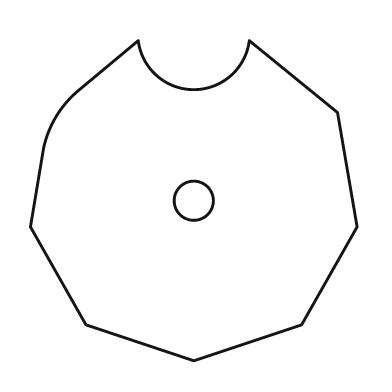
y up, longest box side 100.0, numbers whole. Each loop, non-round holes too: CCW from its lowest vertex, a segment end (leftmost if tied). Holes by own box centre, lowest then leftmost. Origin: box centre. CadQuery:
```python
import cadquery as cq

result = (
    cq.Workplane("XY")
    .moveTo(0.0, -49.0)
    .lineTo(33.0, -38.0)
    .lineTo(50.0, -8.0)
    .lineTo(44.0, 27.0)
    .lineTo(17.0, 49.0)
    .threePointArc((0.0, 34.0), (-17.0, 49.0))
    .lineTo(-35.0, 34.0)
    .threePointArc((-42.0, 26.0), (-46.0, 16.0))
    .lineTo(-50.0, -8.0)
    .lineTo(-33.0, -38.0)
    .close()
    .moveTo(0.0, 0.0)
    .circle(6.0)
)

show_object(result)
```